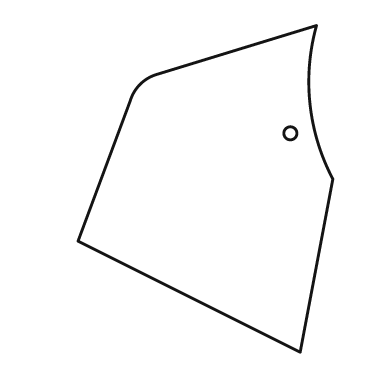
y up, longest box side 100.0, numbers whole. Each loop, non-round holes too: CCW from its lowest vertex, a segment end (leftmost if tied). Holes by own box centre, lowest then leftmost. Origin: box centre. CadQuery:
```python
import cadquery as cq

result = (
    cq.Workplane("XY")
    .moveTo(29.0, -50.0)
    .lineTo(39.0, 3.0)
    .threePointArc((32.0, 26.0), (34.0, 50.0))
    .lineTo(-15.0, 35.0)
    .threePointArc((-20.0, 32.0), (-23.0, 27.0))
    .lineTo(-39.0, -16.0)
    .close()
    .moveTo(26.0, 17.0)
    .circle(2.0)
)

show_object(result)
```